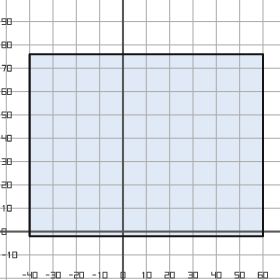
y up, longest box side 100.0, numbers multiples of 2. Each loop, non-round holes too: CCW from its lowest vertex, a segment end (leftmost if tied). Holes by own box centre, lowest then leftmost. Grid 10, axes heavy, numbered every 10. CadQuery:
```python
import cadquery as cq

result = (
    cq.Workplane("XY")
    .moveTo(-40.0, -2.0)
    .lineTo(60.0, -2.0)
    .lineTo(60.0, 76.0)
    .lineTo(-40.0, 76.0)
    .close()
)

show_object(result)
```